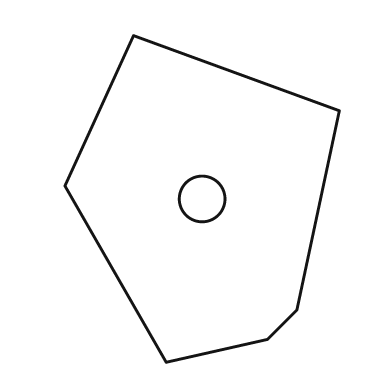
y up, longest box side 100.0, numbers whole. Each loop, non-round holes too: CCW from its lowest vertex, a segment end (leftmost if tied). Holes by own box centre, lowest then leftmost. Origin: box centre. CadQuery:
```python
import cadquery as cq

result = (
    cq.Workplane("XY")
    .moveTo(-11.0, -50.0)
    .lineTo(20.0, -43.0)
    .lineTo(29.0, -34.0)
    .lineTo(42.0, 27.0)
    .lineTo(-21.0, 50.0)
    .lineTo(-42.0, 4.0)
    .close()
    .moveTo(0.0, 0.0)
    .circle(7.0)
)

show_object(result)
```